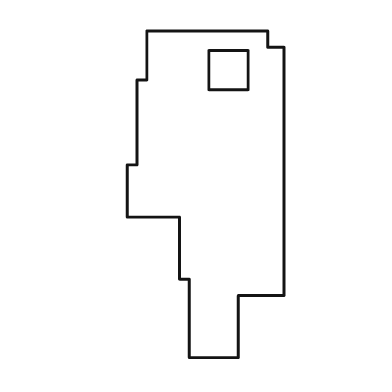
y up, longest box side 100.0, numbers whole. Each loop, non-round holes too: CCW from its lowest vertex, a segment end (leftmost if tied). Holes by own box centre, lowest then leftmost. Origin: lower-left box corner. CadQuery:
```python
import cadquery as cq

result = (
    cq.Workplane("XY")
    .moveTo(19.0, 0.0)
    .lineTo(34.0, 0.0)
    .lineTo(34.0, 19.0)
    .lineTo(48.0, 19.0)
    .lineTo(48.0, 95.0)
    .lineTo(43.0, 95.0)
    .lineTo(43.0, 100.0)
    .lineTo(6.0, 100.0)
    .lineTo(6.0, 85.0)
    .lineTo(3.0, 85.0)
    .lineTo(3.0, 59.0)
    .lineTo(0.0, 59.0)
    .lineTo(0.0, 43.0)
    .lineTo(16.0, 43.0)
    .lineTo(16.0, 24.0)
    .lineTo(19.0, 24.0)
    .close()
    .moveTo(25.0, 82.0)
    .lineTo(37.0, 82.0)
    .lineTo(37.0, 94.0)
    .lineTo(25.0, 94.0)
    .close()
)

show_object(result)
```